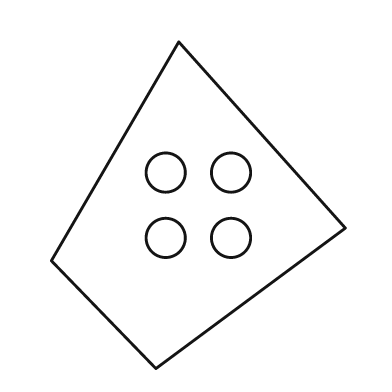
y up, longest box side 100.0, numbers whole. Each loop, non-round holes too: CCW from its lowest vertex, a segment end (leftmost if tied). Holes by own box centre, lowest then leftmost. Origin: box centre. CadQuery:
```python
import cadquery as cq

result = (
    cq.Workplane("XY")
    .moveTo(-13.0, -50.0)
    .lineTo(45.0, -7.0)
    .lineTo(-6.0, 50.0)
    .lineTo(-45.0, -17.0)
    .close()
    .moveTo(-10.0, -10.0)
    .circle(6.0)
    .moveTo(10.0, -10.0)
    .circle(6.0)
    .moveTo(-10.0, 10.0)
    .circle(6.0)
    .moveTo(10.0, 10.0)
    .circle(6.0)
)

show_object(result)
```